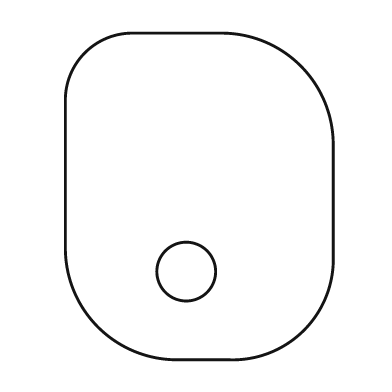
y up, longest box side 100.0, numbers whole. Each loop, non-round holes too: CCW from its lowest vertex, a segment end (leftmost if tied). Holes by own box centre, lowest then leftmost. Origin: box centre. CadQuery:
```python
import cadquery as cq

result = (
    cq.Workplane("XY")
    .moveTo(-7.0, -50.0)
    .lineTo(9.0, -50.0)
    .threePointArc((32.0, -41.0), (41.0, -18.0))
    .lineTo(41.0, 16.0)
    .threePointArc((31.0, 40.0), (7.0, 50.0))
    .lineTo(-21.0, 50.0)
    .threePointArc((-35.0, 44.0), (-41.0, 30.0))
    .lineTo(-41.0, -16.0)
    .threePointArc((-31.0, -40.0), (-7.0, -50.0))
    .close()
    .moveTo(-4.0, -23.0)
    .circle(9.0)
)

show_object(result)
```